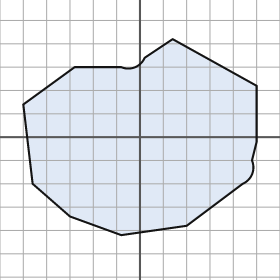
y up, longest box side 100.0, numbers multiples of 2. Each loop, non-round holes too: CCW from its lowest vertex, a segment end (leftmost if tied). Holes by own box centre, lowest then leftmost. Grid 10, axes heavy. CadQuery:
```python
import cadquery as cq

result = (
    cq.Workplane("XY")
    .moveTo(-8.0, -42.0)
    .lineTo(20.0, -38.0)
    .lineTo(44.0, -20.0)
    .threePointArc((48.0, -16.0), (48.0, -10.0))
    .lineTo(50.0, -2.0)
    .lineTo(50.0, 22.0)
    .lineTo(14.0, 42.0)
    .lineTo(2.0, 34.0)
    .threePointArc((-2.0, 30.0), (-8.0, 30.0))
    .lineTo(-28.0, 30.0)
    .lineTo(-50.0, 14.0)
    .lineTo(-46.0, -20.0)
    .lineTo(-30.0, -34.0)
    .close()
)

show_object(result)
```